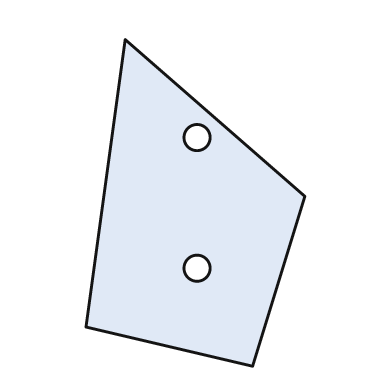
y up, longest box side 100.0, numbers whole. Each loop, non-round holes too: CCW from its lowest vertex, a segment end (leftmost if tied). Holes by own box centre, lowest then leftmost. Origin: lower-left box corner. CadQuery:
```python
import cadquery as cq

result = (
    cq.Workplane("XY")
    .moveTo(51.0, 0.0)
    .lineTo(67.0, 52.0)
    .lineTo(12.0, 100.0)
    .lineTo(0.0, 12.0)
    .close()
    .moveTo(34.0, 30.0)
    .circle(4.0)
    .moveTo(34.0, 70.0)
    .circle(4.0)
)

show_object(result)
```